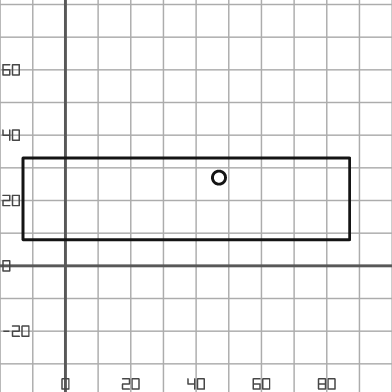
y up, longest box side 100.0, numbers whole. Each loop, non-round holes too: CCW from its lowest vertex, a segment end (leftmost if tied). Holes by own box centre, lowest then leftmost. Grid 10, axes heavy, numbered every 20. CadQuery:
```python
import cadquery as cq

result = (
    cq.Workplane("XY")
    .moveTo(-13.0, 8.0)
    .lineTo(87.0, 8.0)
    .lineTo(87.0, 33.0)
    .lineTo(-13.0, 33.0)
    .close()
    .moveTo(47.0, 27.0)
    .circle(2.0)
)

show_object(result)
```